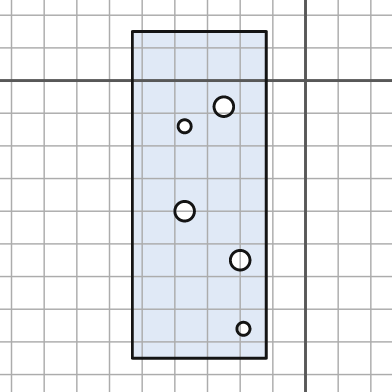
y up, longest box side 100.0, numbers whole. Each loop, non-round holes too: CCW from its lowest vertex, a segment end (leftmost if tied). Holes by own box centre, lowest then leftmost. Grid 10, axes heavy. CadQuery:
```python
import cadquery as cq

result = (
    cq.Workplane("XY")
    .moveTo(-53.0, -85.0)
    .lineTo(-12.0, -85.0)
    .lineTo(-12.0, 15.0)
    .lineTo(-53.0, 15.0)
    .close()
    .moveTo(-19.0, -76.0)
    .circle(2.0)
    .moveTo(-20.0, -55.0)
    .circle(3.0)
    .moveTo(-37.0, -40.0)
    .circle(3.0)
    .moveTo(-37.0, -14.0)
    .circle(2.0)
    .moveTo(-25.0, -8.0)
    .circle(3.0)
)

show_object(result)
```